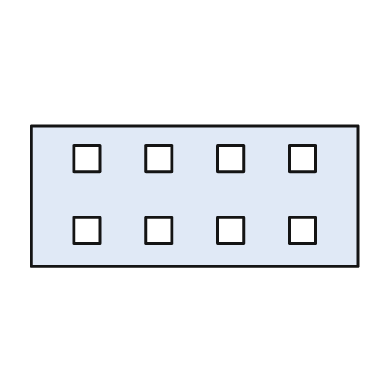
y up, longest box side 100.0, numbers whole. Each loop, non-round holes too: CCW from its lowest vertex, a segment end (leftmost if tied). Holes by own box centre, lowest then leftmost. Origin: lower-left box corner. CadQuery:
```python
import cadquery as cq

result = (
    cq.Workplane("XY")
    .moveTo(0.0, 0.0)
    .lineTo(100.0, 0.0)
    .lineTo(100.0, 43.0)
    .lineTo(0.0, 43.0)
    .close()
    .moveTo(13.0, 7.0)
    .lineTo(21.0, 7.0)
    .lineTo(21.0, 15.0)
    .lineTo(13.0, 15.0)
    .close()
    .moveTo(35.0, 7.0)
    .lineTo(43.0, 7.0)
    .lineTo(43.0, 15.0)
    .lineTo(35.0, 15.0)
    .close()
    .moveTo(57.0, 7.0)
    .lineTo(65.0, 7.0)
    .lineTo(65.0, 15.0)
    .lineTo(57.0, 15.0)
    .close()
    .moveTo(79.0, 7.0)
    .lineTo(87.0, 7.0)
    .lineTo(87.0, 15.0)
    .lineTo(79.0, 15.0)
    .close()
    .moveTo(13.0, 29.0)
    .lineTo(21.0, 29.0)
    .lineTo(21.0, 37.0)
    .lineTo(13.0, 37.0)
    .close()
    .moveTo(35.0, 29.0)
    .lineTo(43.0, 29.0)
    .lineTo(43.0, 37.0)
    .lineTo(35.0, 37.0)
    .close()
    .moveTo(57.0, 29.0)
    .lineTo(65.0, 29.0)
    .lineTo(65.0, 37.0)
    .lineTo(57.0, 37.0)
    .close()
    .moveTo(79.0, 29.0)
    .lineTo(87.0, 29.0)
    .lineTo(87.0, 37.0)
    .lineTo(79.0, 37.0)
    .close()
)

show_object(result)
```